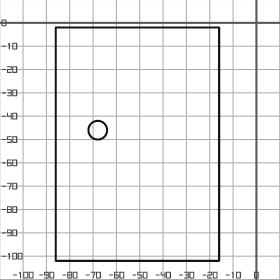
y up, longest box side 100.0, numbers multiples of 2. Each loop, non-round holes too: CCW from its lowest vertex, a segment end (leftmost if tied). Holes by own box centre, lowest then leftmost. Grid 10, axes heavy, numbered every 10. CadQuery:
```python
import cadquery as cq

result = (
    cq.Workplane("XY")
    .moveTo(-86.0, -102.0)
    .lineTo(-16.0, -102.0)
    .lineTo(-16.0, -2.0)
    .lineTo(-86.0, -2.0)
    .close()
    .moveTo(-68.0, -46.0)
    .circle(4.0)
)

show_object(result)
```